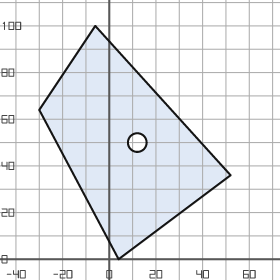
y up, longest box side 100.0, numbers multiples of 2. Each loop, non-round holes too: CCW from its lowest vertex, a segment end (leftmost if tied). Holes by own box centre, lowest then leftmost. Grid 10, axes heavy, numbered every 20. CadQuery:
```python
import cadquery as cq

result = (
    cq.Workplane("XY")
    .moveTo(4.0, 0.0)
    .lineTo(52.0, 36.0)
    .lineTo(-6.0, 100.0)
    .lineTo(-30.0, 64.0)
    .close()
    .moveTo(12.0, 50.0)
    .circle(4.0)
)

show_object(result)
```